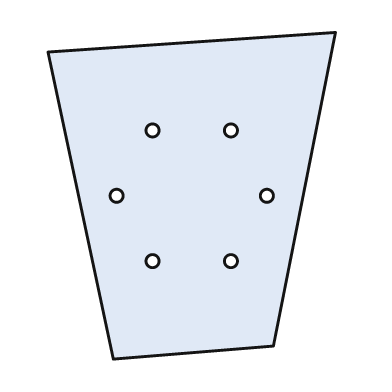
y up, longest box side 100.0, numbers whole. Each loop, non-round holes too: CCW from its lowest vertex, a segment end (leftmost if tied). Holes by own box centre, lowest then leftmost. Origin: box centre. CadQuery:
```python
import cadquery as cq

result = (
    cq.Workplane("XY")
    .moveTo(-24.0, -50.0)
    .lineTo(25.0, -46.0)
    .lineTo(44.0, 50.0)
    .lineTo(-44.0, 44.0)
    .close()
    .moveTo(-12.0, -20.0)
    .circle(2.0)
    .moveTo(12.0, -20.0)
    .circle(2.0)
    .moveTo(-23.0, 0.0)
    .circle(2.0)
    .moveTo(23.0, 0.0)
    .circle(2.0)
    .moveTo(-12.0, 20.0)
    .circle(2.0)
    .moveTo(12.0, 20.0)
    .circle(2.0)
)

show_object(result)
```